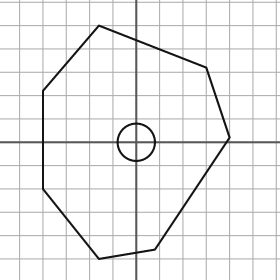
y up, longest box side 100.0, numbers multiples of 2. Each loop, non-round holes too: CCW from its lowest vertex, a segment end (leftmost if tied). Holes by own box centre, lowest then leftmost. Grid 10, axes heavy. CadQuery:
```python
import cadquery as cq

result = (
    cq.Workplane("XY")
    .moveTo(-16.0, -50.0)
    .lineTo(8.0, -46.0)
    .lineTo(40.0, 2.0)
    .lineTo(30.0, 32.0)
    .lineTo(-16.0, 50.0)
    .lineTo(-40.0, 22.0)
    .lineTo(-40.0, -20.0)
    .close()
    .moveTo(0.0, 0.0)
    .circle(8.0)
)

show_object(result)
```